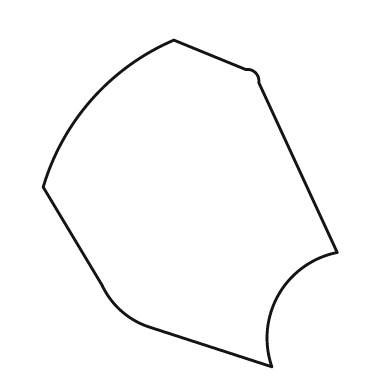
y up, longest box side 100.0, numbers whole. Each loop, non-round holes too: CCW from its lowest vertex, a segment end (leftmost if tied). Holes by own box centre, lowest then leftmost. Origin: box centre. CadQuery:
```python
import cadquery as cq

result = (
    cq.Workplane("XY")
    .moveTo(25.0, -50.0)
    .threePointArc((27.0, -28.0), (45.0, -15.0))
    .lineTo(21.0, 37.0)
    .threePointArc((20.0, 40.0), (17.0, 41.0))
    .lineTo(-5.0, 50.0)
    .threePointArc((-30.0, 32.0), (-45.0, 5.0))
    .lineTo(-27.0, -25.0)
    .threePointArc((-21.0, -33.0), (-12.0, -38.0))
    .close()
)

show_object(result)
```